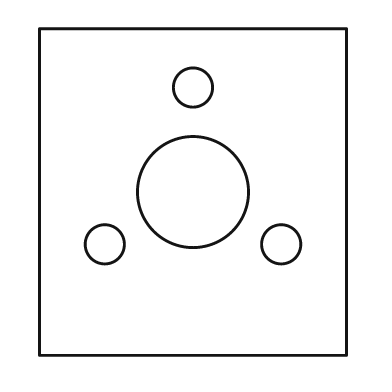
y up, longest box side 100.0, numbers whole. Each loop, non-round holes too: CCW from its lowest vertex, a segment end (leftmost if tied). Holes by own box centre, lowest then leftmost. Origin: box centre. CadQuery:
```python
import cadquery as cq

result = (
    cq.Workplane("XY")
    .moveTo(-47.0, -50.0)
    .lineTo(47.0, -50.0)
    .lineTo(47.0, 50.0)
    .lineTo(-47.0, 50.0)
    .close()
    .moveTo(-27.0, -16.0)
    .circle(6.0)
    .moveTo(27.0, -16.0)
    .circle(6.0)
    .moveTo(0.0, 0.0)
    .circle(17.0)
    .moveTo(0.0, 32.0)
    .circle(6.0)
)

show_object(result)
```